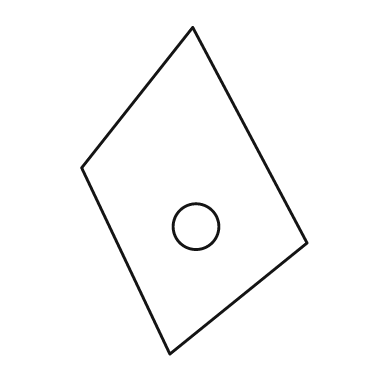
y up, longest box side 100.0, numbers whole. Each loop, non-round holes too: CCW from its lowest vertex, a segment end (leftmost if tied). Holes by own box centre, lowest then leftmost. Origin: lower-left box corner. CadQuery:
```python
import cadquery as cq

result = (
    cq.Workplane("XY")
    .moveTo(27.0, 0.0)
    .lineTo(69.0, 34.0)
    .lineTo(34.0, 100.0)
    .lineTo(0.0, 57.0)
    .close()
    .moveTo(35.0, 39.0)
    .circle(7.0)
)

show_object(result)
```